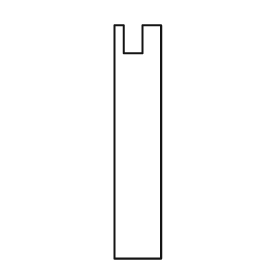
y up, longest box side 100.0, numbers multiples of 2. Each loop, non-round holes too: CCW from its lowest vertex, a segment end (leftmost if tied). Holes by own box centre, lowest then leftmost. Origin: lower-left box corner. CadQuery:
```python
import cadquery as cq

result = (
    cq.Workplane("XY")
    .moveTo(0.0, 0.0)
    .lineTo(20.0, 0.0)
    .lineTo(20.0, 100.0)
    .lineTo(12.0, 100.0)
    .lineTo(12.0, 88.0)
    .lineTo(4.0, 88.0)
    .lineTo(4.0, 100.0)
    .lineTo(0.0, 100.0)
    .close()
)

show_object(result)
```